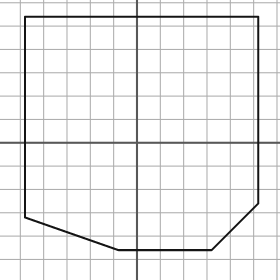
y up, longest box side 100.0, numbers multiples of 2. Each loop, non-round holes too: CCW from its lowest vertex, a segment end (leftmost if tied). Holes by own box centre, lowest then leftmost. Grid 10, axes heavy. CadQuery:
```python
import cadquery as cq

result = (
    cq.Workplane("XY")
    .moveTo(-8.0, -46.0)
    .lineTo(32.0, -46.0)
    .lineTo(52.0, -26.0)
    .lineTo(52.0, 54.0)
    .lineTo(-48.0, 54.0)
    .lineTo(-48.0, -32.0)
    .close()
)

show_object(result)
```